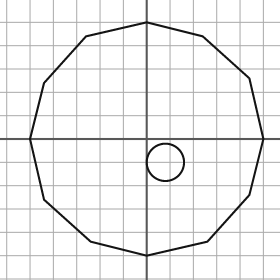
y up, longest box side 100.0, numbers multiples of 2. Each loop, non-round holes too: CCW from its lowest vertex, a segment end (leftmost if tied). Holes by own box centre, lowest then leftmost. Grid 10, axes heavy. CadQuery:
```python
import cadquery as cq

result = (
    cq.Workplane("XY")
    .moveTo(0.0, -50.0)
    .lineTo(26.0, -44.0)
    .lineTo(44.0, -24.0)
    .lineTo(50.0, 0.0)
    .lineTo(44.0, 26.0)
    .lineTo(24.0, 44.0)
    .lineTo(0.0, 50.0)
    .lineTo(-26.0, 44.0)
    .lineTo(-44.0, 24.0)
    .lineTo(-50.0, 0.0)
    .lineTo(-44.0, -26.0)
    .lineTo(-24.0, -44.0)
    .close()
    .moveTo(8.0, -10.0)
    .circle(8.0)
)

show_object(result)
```